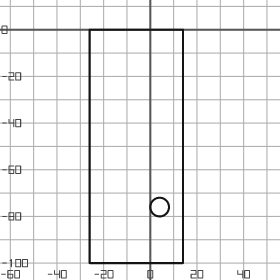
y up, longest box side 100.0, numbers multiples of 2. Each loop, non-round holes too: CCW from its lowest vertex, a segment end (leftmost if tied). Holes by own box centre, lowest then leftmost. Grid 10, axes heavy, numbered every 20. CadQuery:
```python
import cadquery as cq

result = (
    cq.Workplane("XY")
    .moveTo(-26.0, -100.0)
    .lineTo(14.0, -100.0)
    .lineTo(14.0, 0.0)
    .lineTo(-26.0, 0.0)
    .close()
    .moveTo(4.0, -76.0)
    .circle(4.0)
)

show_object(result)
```